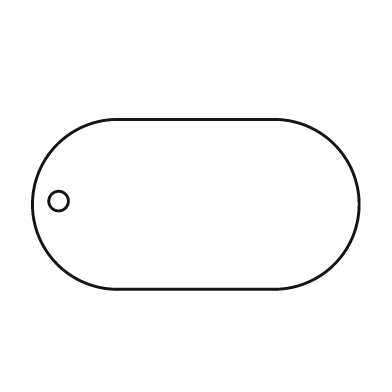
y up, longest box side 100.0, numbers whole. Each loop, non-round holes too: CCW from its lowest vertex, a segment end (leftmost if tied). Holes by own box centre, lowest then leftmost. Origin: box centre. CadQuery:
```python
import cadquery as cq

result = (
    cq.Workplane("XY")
    .moveTo(-24.0, -26.0)
    .lineTo(24.0, -26.0)
    .threePointArc((50.0, 0.0), (24.0, 26.0))
    .lineTo(-24.0, 26.0)
    .threePointArc((-50.0, 0.0), (-24.0, -26.0))
    .close()
    .moveTo(-42.0, 1.0)
    .circle(3.0)
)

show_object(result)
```